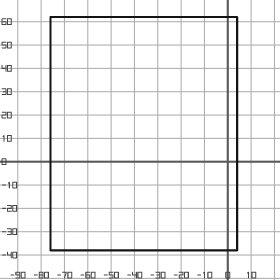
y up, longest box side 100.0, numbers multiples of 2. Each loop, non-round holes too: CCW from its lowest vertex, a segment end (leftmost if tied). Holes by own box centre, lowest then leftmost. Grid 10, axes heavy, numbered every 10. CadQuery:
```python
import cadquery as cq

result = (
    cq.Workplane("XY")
    .moveTo(-76.0, -38.0)
    .lineTo(4.0, -38.0)
    .lineTo(4.0, 62.0)
    .lineTo(-76.0, 62.0)
    .close()
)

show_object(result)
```